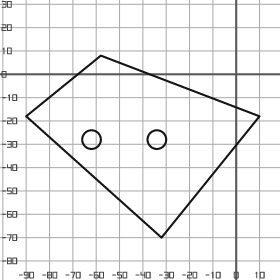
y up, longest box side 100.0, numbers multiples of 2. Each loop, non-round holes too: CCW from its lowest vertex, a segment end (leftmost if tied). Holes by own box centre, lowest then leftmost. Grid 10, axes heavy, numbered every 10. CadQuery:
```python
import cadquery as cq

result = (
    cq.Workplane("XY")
    .moveTo(-32.0, -70.0)
    .lineTo(10.0, -18.0)
    .lineTo(-58.0, 8.0)
    .lineTo(-90.0, -18.0)
    .close()
    .moveTo(-62.0, -28.0)
    .circle(4.0)
    .moveTo(-34.0, -28.0)
    .circle(4.0)
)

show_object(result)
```